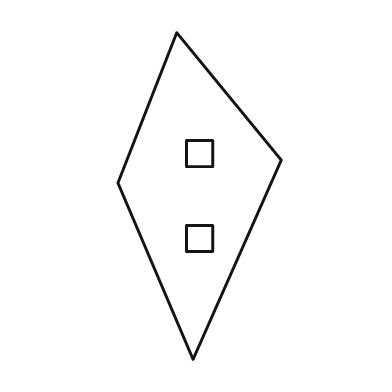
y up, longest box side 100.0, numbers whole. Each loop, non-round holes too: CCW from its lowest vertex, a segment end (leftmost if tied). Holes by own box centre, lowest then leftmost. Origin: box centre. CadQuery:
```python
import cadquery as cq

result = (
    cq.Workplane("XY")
    .moveTo(-2.0, -50.0)
    .lineTo(25.0, 11.0)
    .lineTo(-7.0, 50.0)
    .lineTo(-25.0, 4.0)
    .close()
    .moveTo(-4.0, -17.0)
    .lineTo(4.0, -17.0)
    .lineTo(4.0, -9.0)
    .lineTo(-4.0, -9.0)
    .close()
    .moveTo(-4.0, 9.0)
    .lineTo(4.0, 9.0)
    .lineTo(4.0, 17.0)
    .lineTo(-4.0, 17.0)
    .close()
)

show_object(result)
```